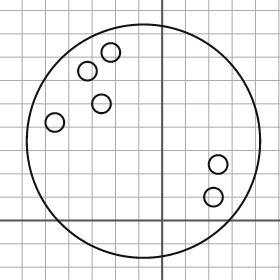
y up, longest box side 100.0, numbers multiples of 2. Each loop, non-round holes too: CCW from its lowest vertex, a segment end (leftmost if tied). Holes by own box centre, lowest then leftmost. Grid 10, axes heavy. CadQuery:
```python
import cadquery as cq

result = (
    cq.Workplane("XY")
    .moveTo(-8.0, 34.0)
    .circle(50.0)
    .moveTo(22.0, 10.0)
    .circle(4.0)
    .moveTo(24.0, 24.0)
    .circle(4.0)
    .moveTo(-46.0, 42.0)
    .circle(4.0)
    .moveTo(-26.0, 50.0)
    .circle(4.0)
    .moveTo(-32.0, 64.0)
    .circle(4.0)
    .moveTo(-22.0, 72.0)
    .circle(4.0)
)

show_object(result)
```